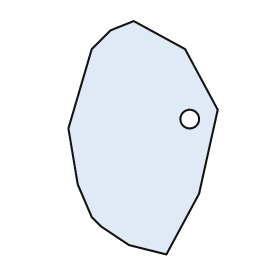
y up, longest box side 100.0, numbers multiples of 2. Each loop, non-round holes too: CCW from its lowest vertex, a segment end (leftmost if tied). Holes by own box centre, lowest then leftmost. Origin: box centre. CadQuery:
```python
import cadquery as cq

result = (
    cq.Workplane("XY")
    .moveTo(10.0, -50.0)
    .lineTo(24.0, -24.0)
    .lineTo(32.0, 12.0)
    .lineTo(18.0, 38.0)
    .lineTo(-4.0, 50.0)
    .lineTo(-14.0, 46.0)
    .lineTo(-22.0, 38.0)
    .lineTo(-32.0, 4.0)
    .lineTo(-28.0, -20.0)
    .lineTo(-22.0, -34.0)
    .lineTo(-18.0, -38.0)
    .lineTo(-6.0, -46.0)
    .close()
    .moveTo(20.0, 8.0)
    .circle(4.0)
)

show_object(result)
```